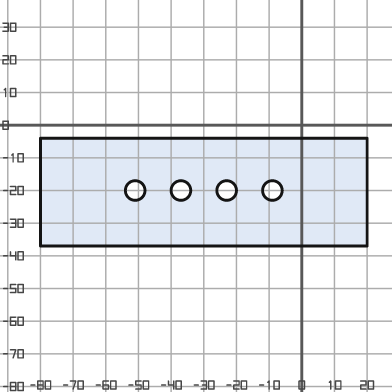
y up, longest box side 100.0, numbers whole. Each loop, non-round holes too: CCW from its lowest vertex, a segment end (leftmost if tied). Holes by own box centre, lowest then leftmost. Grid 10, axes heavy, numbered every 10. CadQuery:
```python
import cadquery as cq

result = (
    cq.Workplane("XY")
    .moveTo(-80.0, -37.0)
    .lineTo(20.0, -37.0)
    .lineTo(20.0, -4.0)
    .lineTo(-80.0, -4.0)
    .close()
    .moveTo(-51.0, -20.0)
    .circle(3.0)
    .moveTo(-37.0, -20.0)
    .circle(3.0)
    .moveTo(-23.0, -20.0)
    .circle(3.0)
    .moveTo(-9.0, -20.0)
    .circle(3.0)
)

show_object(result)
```